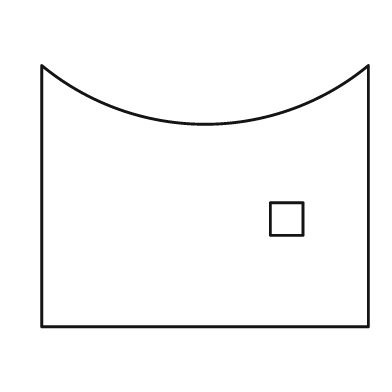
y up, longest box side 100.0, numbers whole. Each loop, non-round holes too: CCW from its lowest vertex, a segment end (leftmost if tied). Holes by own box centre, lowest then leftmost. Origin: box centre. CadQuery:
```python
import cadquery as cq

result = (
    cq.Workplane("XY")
    .moveTo(-50.0, -40.0)
    .lineTo(50.0, -40.0)
    .lineTo(50.0, 40.0)
    .threePointArc((0.0, 22.0), (-50.0, 40.0))
    .close()
    .moveTo(20.0, -12.0)
    .lineTo(30.0, -12.0)
    .lineTo(30.0, -2.0)
    .lineTo(20.0, -2.0)
    .close()
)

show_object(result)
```